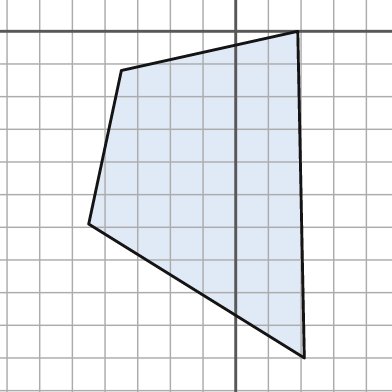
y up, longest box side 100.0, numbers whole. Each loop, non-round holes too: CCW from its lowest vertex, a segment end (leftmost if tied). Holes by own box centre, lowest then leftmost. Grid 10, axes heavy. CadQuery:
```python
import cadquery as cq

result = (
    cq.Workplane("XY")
    .moveTo(21.0, -100.0)
    .lineTo(19.0, 0.0)
    .lineTo(-35.0, -12.0)
    .lineTo(-45.0, -59.0)
    .close()
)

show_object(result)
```